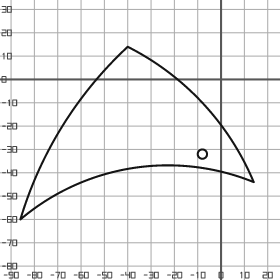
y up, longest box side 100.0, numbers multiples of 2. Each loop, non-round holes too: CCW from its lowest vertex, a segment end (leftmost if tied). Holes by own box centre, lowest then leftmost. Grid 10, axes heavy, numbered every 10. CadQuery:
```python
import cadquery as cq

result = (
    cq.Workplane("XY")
    .moveTo(-86.0, -60.0)
    .threePointArc((-38.0, -38.0), (14.0, -44.0))
    .threePointArc((-8.0, -10.0), (-40.0, 14.0))
    .threePointArc((-68.0, -20.0), (-86.0, -60.0))
    .close()
    .moveTo(-8.0, -32.0)
    .circle(2.0)
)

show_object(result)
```